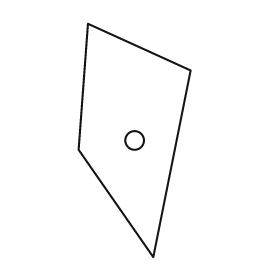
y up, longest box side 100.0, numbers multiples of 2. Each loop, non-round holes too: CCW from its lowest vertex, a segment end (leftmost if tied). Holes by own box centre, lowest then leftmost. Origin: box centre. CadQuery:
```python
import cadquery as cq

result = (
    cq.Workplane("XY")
    .moveTo(8.0, -50.0)
    .lineTo(24.0, 30.0)
    .lineTo(-20.0, 50.0)
    .lineTo(-24.0, -4.0)
    .close()
    .moveTo(0.0, 0.0)
    .circle(4.0)
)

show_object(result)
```